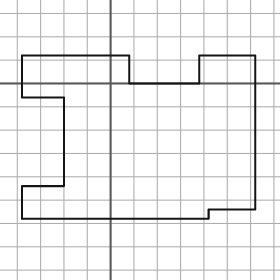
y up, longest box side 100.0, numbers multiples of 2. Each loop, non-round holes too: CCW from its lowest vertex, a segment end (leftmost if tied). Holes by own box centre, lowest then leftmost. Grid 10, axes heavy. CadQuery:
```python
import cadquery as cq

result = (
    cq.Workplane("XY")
    .moveTo(-38.0, -58.0)
    .lineTo(42.0, -58.0)
    .lineTo(42.0, -54.0)
    .lineTo(62.0, -54.0)
    .lineTo(62.0, 12.0)
    .lineTo(38.0, 12.0)
    .lineTo(38.0, 0.0)
    .lineTo(8.0, 0.0)
    .lineTo(8.0, 12.0)
    .lineTo(-38.0, 12.0)
    .lineTo(-38.0, -6.0)
    .lineTo(-20.0, -6.0)
    .lineTo(-20.0, -44.0)
    .lineTo(-38.0, -44.0)
    .close()
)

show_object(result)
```